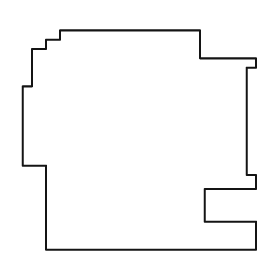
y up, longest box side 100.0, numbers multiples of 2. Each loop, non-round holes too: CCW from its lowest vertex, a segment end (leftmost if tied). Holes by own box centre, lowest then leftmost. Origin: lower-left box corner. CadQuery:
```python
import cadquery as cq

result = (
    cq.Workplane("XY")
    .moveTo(10.0, 0.0)
    .lineTo(100.0, 0.0)
    .lineTo(100.0, 12.0)
    .lineTo(78.0, 12.0)
    .lineTo(78.0, 26.0)
    .lineTo(100.0, 26.0)
    .lineTo(100.0, 32.0)
    .lineTo(96.0, 32.0)
    .lineTo(96.0, 78.0)
    .lineTo(100.0, 78.0)
    .lineTo(100.0, 82.0)
    .lineTo(76.0, 82.0)
    .lineTo(76.0, 94.0)
    .lineTo(16.0, 94.0)
    .lineTo(16.0, 90.0)
    .lineTo(10.0, 90.0)
    .lineTo(10.0, 86.0)
    .lineTo(4.0, 86.0)
    .lineTo(4.0, 70.0)
    .lineTo(0.0, 70.0)
    .lineTo(0.0, 36.0)
    .lineTo(10.0, 36.0)
    .close()
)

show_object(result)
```